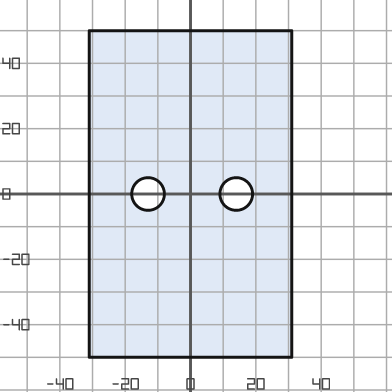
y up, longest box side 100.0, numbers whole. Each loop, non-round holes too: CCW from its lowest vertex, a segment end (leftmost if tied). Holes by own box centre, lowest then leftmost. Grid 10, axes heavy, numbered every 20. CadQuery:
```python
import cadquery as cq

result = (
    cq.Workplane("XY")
    .moveTo(-31.0, -50.0)
    .lineTo(31.0, -50.0)
    .lineTo(31.0, 50.0)
    .lineTo(-31.0, 50.0)
    .close()
    .moveTo(-13.0, 0.0)
    .circle(5.0)
    .moveTo(14.0, 0.0)
    .circle(5.0)
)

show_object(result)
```